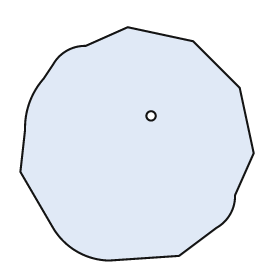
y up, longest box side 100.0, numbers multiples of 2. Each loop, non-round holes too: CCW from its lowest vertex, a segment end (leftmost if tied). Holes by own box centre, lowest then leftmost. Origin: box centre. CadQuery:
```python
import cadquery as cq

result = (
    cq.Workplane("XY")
    .moveTo(-12.0, -50.0)
    .lineTo(18.0, -48.0)
    .lineTo(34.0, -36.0)
    .threePointArc((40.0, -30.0), (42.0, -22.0))
    .lineTo(50.0, -4.0)
    .lineTo(44.0, 24.0)
    .lineTo(24.0, 44.0)
    .lineTo(-4.0, 50.0)
    .lineTo(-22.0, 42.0)
    .threePointArc((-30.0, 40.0), (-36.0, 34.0))
    .lineTo(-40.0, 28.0)
    .threePointArc((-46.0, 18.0), (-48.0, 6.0))
    .lineTo(-50.0, -12.0)
    .lineTo(-36.0, -36.0)
    .threePointArc((-26.0, -46.0), (-12.0, -50.0))
    .close()
    .moveTo(6.0, 12.0)
    .circle(2.0)
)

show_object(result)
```